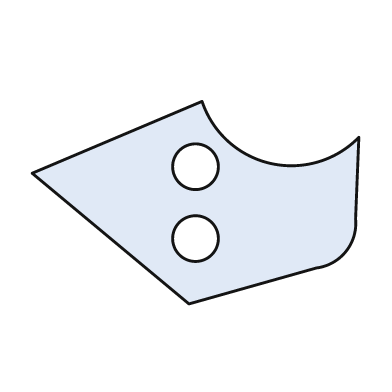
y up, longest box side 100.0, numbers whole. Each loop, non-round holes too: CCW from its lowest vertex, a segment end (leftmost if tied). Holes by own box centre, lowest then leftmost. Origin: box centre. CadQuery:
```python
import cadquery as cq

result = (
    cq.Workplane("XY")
    .moveTo(-2.0, -31.0)
    .lineTo(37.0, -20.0)
    .threePointArc((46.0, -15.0), (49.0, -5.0))
    .lineTo(50.0, 20.0)
    .threePointArc((23.0, 12.0), (2.0, 31.0))
    .lineTo(-50.0, 9.0)
    .close()
    .moveTo(0.0, -11.0)
    .circle(7.0)
    .moveTo(0.0, 11.0)
    .circle(7.0)
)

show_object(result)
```